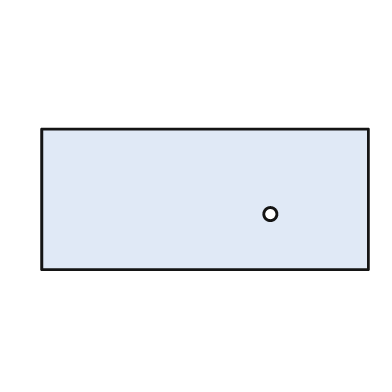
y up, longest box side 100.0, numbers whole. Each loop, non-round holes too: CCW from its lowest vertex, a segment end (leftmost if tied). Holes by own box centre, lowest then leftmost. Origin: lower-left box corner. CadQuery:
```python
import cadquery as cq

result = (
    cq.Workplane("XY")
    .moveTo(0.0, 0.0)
    .lineTo(100.0, 0.0)
    .lineTo(100.0, 43.0)
    .lineTo(0.0, 43.0)
    .close()
    .moveTo(70.0, 17.0)
    .circle(2.0)
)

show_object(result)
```